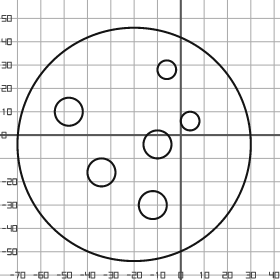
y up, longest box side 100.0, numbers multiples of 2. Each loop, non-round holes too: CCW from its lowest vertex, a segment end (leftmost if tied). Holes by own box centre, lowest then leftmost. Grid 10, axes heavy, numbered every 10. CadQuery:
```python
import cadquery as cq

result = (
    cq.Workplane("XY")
    .moveTo(-20.0, -4.0)
    .circle(50.0)
    .moveTo(-12.0, -30.0)
    .circle(6.0)
    .moveTo(-34.0, -16.0)
    .circle(6.0)
    .moveTo(-10.0, -4.0)
    .circle(6.0)
    .moveTo(4.0, 6.0)
    .circle(4.0)
    .moveTo(-48.0, 10.0)
    .circle(6.0)
    .moveTo(-6.0, 28.0)
    .circle(4.0)
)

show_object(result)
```